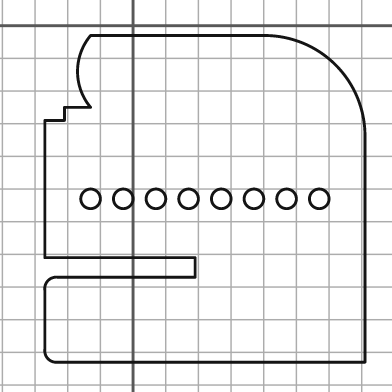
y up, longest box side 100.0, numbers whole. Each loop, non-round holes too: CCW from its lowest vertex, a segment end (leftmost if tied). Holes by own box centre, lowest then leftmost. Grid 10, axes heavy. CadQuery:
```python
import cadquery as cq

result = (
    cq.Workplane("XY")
    .moveTo(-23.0, -103.0)
    .lineTo(71.0, -103.0)
    .lineTo(71.0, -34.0)
    .threePointArc((62.0, -12.0), (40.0, -3.0))
    .lineTo(-13.0, -3.0)
    .threePointArc((-17.0, -14.0), (-13.0, -25.0))
    .lineTo(-21.0, -25.0)
    .lineTo(-21.0, -29.0)
    .lineTo(-27.0, -29.0)
    .lineTo(-27.0, -71.0)
    .lineTo(19.0, -71.0)
    .lineTo(19.0, -77.0)
    .lineTo(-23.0, -77.0)
    .threePointArc((-26.0, -78.0), (-27.0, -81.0))
    .lineTo(-27.0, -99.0)
    .threePointArc((-26.0, -102.0), (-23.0, -103.0))
    .close()
    .moveTo(-13.0, -53.0)
    .circle(3.0)
    .moveTo(-3.0, -53.0)
    .circle(3.0)
    .moveTo(7.0, -53.0)
    .circle(3.0)
    .moveTo(17.0, -53.0)
    .circle(3.0)
    .moveTo(27.0, -53.0)
    .circle(3.0)
    .moveTo(37.0, -53.0)
    .circle(3.0)
    .moveTo(47.0, -53.0)
    .circle(3.0)
    .moveTo(57.0, -53.0)
    .circle(3.0)
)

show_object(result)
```